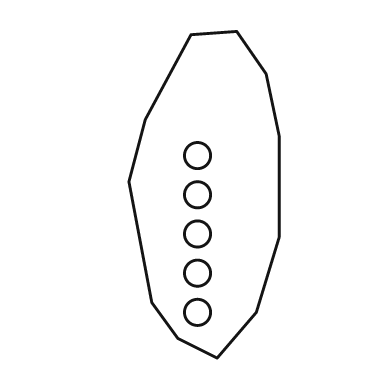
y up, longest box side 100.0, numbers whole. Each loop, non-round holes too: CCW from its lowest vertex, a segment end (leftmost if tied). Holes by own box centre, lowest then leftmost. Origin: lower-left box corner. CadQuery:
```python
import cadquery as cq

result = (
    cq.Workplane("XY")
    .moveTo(27.0, 0.0)
    .lineTo(39.0, 14.0)
    .lineTo(46.0, 37.0)
    .lineTo(46.0, 68.0)
    .lineTo(42.0, 87.0)
    .lineTo(33.0, 100.0)
    .lineTo(19.0, 99.0)
    .lineTo(5.0, 73.0)
    .lineTo(0.0, 54.0)
    .lineTo(7.0, 17.0)
    .lineTo(15.0, 6.0)
    .close()
    .moveTo(21.0, 14.0)
    .circle(4.0)
    .moveTo(21.0, 26.0)
    .circle(4.0)
    .moveTo(21.0, 38.0)
    .circle(4.0)
    .moveTo(21.0, 50.0)
    .circle(4.0)
    .moveTo(21.0, 62.0)
    .circle(4.0)
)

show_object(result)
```